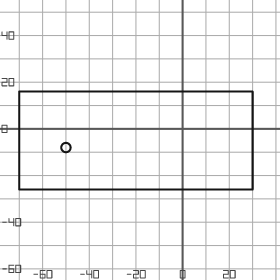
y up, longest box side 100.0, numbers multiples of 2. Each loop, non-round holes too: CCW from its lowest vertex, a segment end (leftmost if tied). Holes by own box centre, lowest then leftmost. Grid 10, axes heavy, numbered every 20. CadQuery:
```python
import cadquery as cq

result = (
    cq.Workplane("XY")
    .moveTo(-70.0, -26.0)
    .lineTo(30.0, -26.0)
    .lineTo(30.0, 16.0)
    .lineTo(-70.0, 16.0)
    .close()
    .moveTo(-50.0, -8.0)
    .circle(2.0)
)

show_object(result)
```